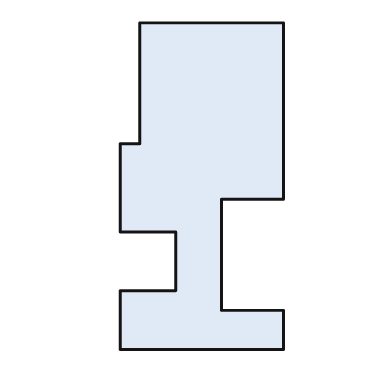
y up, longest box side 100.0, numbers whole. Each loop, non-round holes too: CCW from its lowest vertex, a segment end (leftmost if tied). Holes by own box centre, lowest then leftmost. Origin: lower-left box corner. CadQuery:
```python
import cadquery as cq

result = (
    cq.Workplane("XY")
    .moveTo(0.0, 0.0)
    .lineTo(50.0, 0.0)
    .lineTo(50.0, 12.0)
    .lineTo(31.0, 12.0)
    .lineTo(31.0, 46.0)
    .lineTo(50.0, 46.0)
    .lineTo(50.0, 100.0)
    .lineTo(6.0, 100.0)
    .lineTo(6.0, 63.0)
    .lineTo(0.0, 63.0)
    .lineTo(0.0, 36.0)
    .lineTo(17.0, 36.0)
    .lineTo(17.0, 18.0)
    .lineTo(0.0, 18.0)
    .close()
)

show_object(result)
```